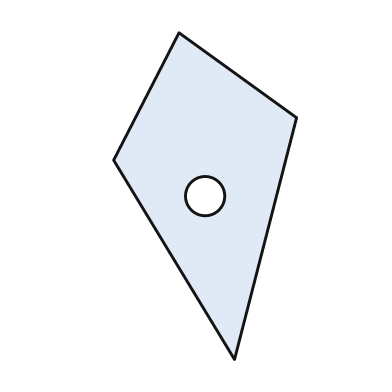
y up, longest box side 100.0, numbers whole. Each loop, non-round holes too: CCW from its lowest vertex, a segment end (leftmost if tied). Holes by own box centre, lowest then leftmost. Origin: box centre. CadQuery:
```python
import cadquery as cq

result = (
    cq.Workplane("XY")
    .moveTo(9.0, -50.0)
    .lineTo(28.0, 24.0)
    .lineTo(-8.0, 50.0)
    .lineTo(-28.0, 11.0)
    .close()
    .moveTo(0.0, 0.0)
    .circle(6.0)
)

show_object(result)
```